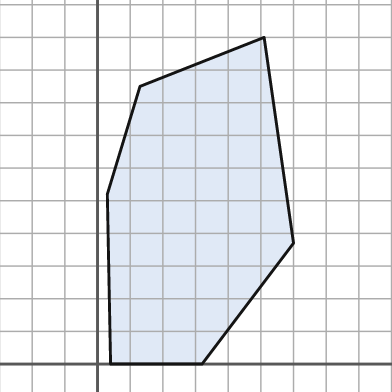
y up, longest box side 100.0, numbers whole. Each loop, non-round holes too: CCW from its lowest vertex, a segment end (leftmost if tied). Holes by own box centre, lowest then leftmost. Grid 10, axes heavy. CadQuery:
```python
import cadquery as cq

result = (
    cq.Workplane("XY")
    .moveTo(4.0, 0.0)
    .lineTo(32.0, 0.0)
    .lineTo(60.0, 37.0)
    .lineTo(51.0, 100.0)
    .lineTo(13.0, 85.0)
    .lineTo(3.0, 52.0)
    .close()
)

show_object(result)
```